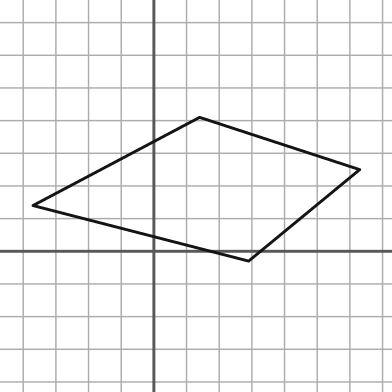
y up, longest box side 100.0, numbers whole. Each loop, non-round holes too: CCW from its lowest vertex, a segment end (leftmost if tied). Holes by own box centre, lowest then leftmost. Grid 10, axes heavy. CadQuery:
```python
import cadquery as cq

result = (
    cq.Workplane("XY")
    .moveTo(29.0, -3.0)
    .lineTo(63.0, 25.0)
    .lineTo(14.0, 41.0)
    .lineTo(-37.0, 14.0)
    .close()
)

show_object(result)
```